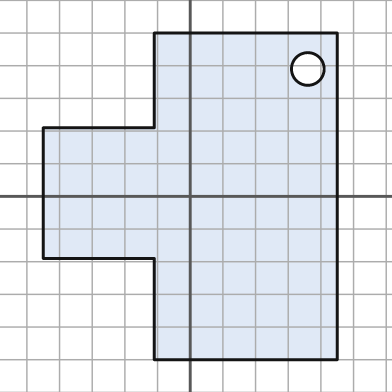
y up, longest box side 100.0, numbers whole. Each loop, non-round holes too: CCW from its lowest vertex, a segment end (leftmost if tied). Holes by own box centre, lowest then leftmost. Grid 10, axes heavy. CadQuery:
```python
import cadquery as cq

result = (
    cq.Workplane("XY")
    .moveTo(-11.0, -50.0)
    .lineTo(45.0, -50.0)
    .lineTo(45.0, 50.0)
    .lineTo(-11.0, 50.0)
    .lineTo(-11.0, 21.0)
    .lineTo(-45.0, 21.0)
    .lineTo(-45.0, -19.0)
    .lineTo(-11.0, -19.0)
    .close()
    .moveTo(36.0, 39.0)
    .circle(5.0)
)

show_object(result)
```